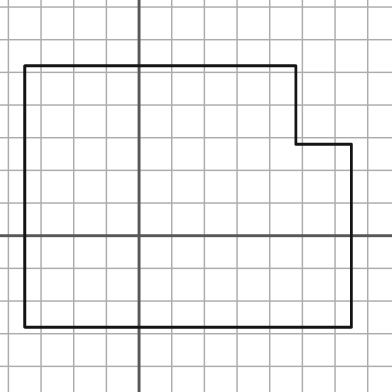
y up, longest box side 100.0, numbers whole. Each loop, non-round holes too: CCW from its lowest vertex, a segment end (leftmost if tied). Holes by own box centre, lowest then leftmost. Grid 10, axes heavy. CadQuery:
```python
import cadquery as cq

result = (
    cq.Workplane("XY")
    .moveTo(-35.0, -28.0)
    .lineTo(65.0, -28.0)
    .lineTo(65.0, 28.0)
    .lineTo(48.0, 28.0)
    .lineTo(48.0, 52.0)
    .lineTo(-35.0, 52.0)
    .close()
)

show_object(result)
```